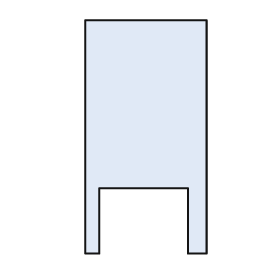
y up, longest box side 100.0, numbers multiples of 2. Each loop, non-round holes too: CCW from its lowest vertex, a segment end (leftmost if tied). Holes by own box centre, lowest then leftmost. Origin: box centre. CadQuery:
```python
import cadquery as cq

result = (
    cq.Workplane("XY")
    .moveTo(-26.0, -50.0)
    .lineTo(-20.0, -50.0)
    .lineTo(-20.0, -22.0)
    .lineTo(18.0, -22.0)
    .lineTo(18.0, -50.0)
    .lineTo(26.0, -50.0)
    .lineTo(26.0, 50.0)
    .lineTo(-26.0, 50.0)
    .close()
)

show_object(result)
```